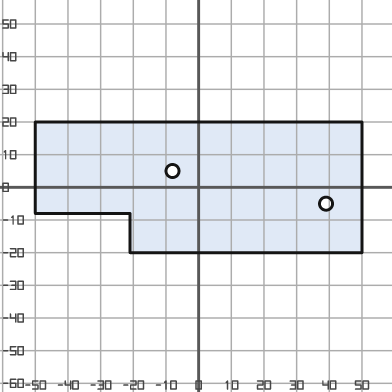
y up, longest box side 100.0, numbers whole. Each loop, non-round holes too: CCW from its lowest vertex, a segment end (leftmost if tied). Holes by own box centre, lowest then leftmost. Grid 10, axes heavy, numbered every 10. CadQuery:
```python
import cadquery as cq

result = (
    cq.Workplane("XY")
    .moveTo(-21.0, -20.0)
    .lineTo(50.0, -20.0)
    .lineTo(50.0, 20.0)
    .lineTo(-50.0, 20.0)
    .lineTo(-50.0, -8.0)
    .lineTo(-21.0, -8.0)
    .close()
    .moveTo(39.0, -5.0)
    .circle(2.0)
    .moveTo(-8.0, 5.0)
    .circle(2.0)
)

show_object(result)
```